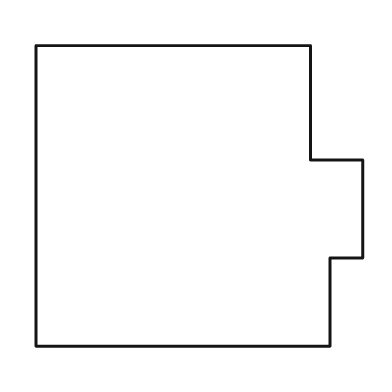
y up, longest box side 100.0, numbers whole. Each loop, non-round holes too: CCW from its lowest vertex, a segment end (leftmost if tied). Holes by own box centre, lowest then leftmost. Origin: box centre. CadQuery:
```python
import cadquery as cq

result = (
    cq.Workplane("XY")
    .moveTo(-50.0, -46.0)
    .lineTo(40.0, -46.0)
    .lineTo(40.0, -19.0)
    .lineTo(50.0, -19.0)
    .lineTo(50.0, 11.0)
    .lineTo(34.0, 11.0)
    .lineTo(34.0, 46.0)
    .lineTo(-50.0, 46.0)
    .close()
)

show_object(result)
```